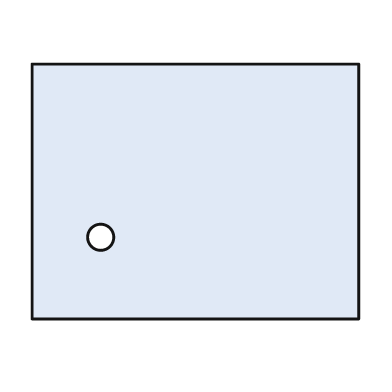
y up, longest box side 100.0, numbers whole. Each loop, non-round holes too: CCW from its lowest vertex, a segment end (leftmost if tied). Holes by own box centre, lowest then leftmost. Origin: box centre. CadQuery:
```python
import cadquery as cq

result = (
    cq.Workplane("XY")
    .moveTo(-50.0, -39.0)
    .lineTo(50.0, -39.0)
    .lineTo(50.0, 39.0)
    .lineTo(-50.0, 39.0)
    .close()
    .moveTo(-29.0, -14.0)
    .circle(4.0)
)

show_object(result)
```